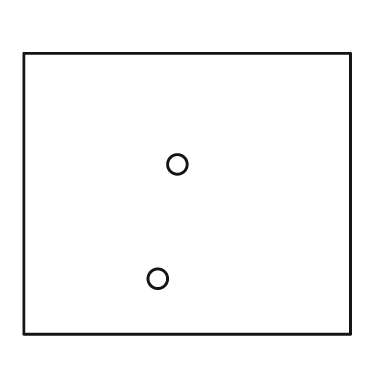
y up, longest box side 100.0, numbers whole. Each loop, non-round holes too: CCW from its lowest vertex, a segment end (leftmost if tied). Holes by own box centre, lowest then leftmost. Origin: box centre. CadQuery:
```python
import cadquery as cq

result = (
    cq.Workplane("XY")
    .moveTo(-50.0, -43.0)
    .lineTo(50.0, -43.0)
    .lineTo(50.0, 43.0)
    .lineTo(-50.0, 43.0)
    .close()
    .moveTo(-9.0, -26.0)
    .circle(3.0)
    .moveTo(-3.0, 9.0)
    .circle(3.0)
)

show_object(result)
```